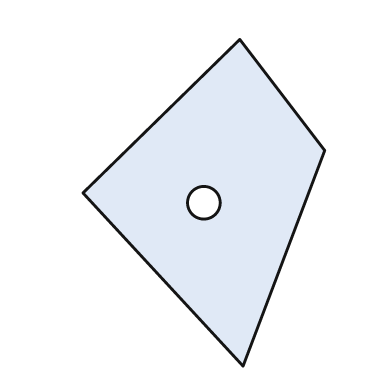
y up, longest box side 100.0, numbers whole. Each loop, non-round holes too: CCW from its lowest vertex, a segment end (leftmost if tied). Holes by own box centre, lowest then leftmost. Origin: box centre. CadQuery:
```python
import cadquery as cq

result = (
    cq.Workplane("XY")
    .moveTo(12.0, -50.0)
    .lineTo(37.0, 16.0)
    .lineTo(11.0, 50.0)
    .lineTo(-37.0, 3.0)
    .close()
    .moveTo(0.0, 0.0)
    .circle(5.0)
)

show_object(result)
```